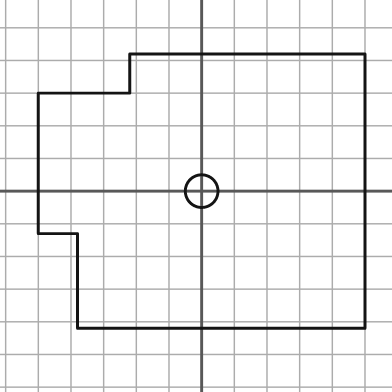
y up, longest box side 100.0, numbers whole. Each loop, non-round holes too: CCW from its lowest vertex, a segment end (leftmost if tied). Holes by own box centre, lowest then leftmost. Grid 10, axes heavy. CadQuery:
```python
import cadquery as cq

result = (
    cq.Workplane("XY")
    .moveTo(-38.0, -42.0)
    .lineTo(50.0, -42.0)
    .lineTo(50.0, 42.0)
    .lineTo(-22.0, 42.0)
    .lineTo(-22.0, 30.0)
    .lineTo(-50.0, 30.0)
    .lineTo(-50.0, -13.0)
    .lineTo(-38.0, -13.0)
    .close()
    .moveTo(0.0, 0.0)
    .circle(5.0)
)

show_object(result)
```